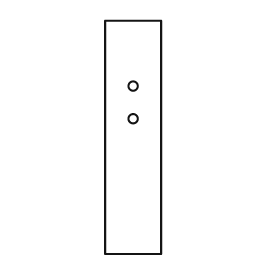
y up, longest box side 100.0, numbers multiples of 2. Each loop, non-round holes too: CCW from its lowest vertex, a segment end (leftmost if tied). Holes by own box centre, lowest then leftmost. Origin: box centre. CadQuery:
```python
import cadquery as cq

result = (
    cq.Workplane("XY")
    .moveTo(-12.0, -50.0)
    .lineTo(12.0, -50.0)
    .lineTo(12.0, 50.0)
    .lineTo(-12.0, 50.0)
    .close()
    .moveTo(0.0, 8.0)
    .circle(2.0)
    .moveTo(0.0, 22.0)
    .circle(2.0)
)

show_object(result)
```